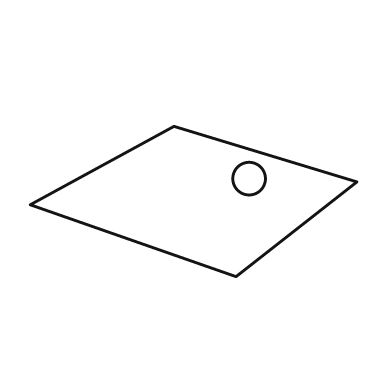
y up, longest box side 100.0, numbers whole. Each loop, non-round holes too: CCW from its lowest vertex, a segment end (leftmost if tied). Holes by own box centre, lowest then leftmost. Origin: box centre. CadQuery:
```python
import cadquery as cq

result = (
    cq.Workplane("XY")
    .moveTo(13.0, -23.0)
    .lineTo(50.0, 6.0)
    .lineTo(-6.0, 23.0)
    .lineTo(-50.0, -1.0)
    .close()
    .moveTo(17.0, 7.0)
    .circle(5.0)
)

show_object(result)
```